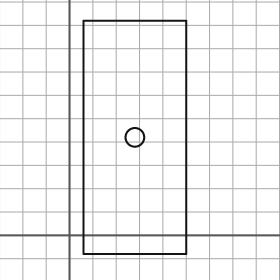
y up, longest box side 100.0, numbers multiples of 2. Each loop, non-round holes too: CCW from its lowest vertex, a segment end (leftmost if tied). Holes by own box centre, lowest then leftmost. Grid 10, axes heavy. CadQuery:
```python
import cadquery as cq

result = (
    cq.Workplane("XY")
    .moveTo(6.0, -8.0)
    .lineTo(50.0, -8.0)
    .lineTo(50.0, 92.0)
    .lineTo(6.0, 92.0)
    .close()
    .moveTo(28.0, 42.0)
    .circle(4.0)
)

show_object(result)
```